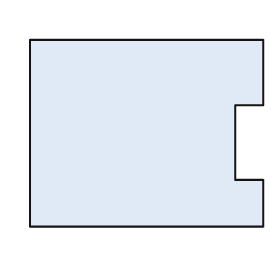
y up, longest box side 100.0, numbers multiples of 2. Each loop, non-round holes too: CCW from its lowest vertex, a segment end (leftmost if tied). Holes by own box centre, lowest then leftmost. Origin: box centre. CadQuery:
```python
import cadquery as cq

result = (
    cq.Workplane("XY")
    .moveTo(-50.0, -40.0)
    .lineTo(50.0, -40.0)
    .lineTo(50.0, -20.0)
    .lineTo(38.0, -20.0)
    .lineTo(38.0, 12.0)
    .lineTo(50.0, 12.0)
    .lineTo(50.0, 40.0)
    .lineTo(-50.0, 40.0)
    .close()
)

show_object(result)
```